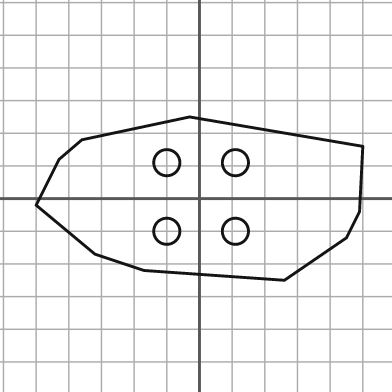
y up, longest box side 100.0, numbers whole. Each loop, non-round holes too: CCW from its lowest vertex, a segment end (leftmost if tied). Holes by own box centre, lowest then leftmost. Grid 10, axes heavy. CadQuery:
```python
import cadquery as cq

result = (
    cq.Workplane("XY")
    .moveTo(26.0, -25.0)
    .lineTo(45.0, -12.0)
    .lineTo(49.0, -4.0)
    .lineTo(50.0, 16.0)
    .lineTo(-3.0, 25.0)
    .lineTo(-36.0, 18.0)
    .lineTo(-43.0, 12.0)
    .lineTo(-50.0, -2.0)
    .lineTo(-32.0, -17.0)
    .lineTo(-17.0, -22.0)
    .close()
    .moveTo(-10.0, -10.0)
    .circle(4.0)
    .moveTo(11.0, -10.0)
    .circle(4.0)
    .moveTo(-10.0, 11.0)
    .circle(4.0)
    .moveTo(11.0, 11.0)
    .circle(4.0)
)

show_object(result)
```